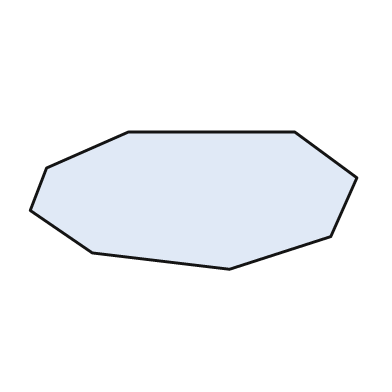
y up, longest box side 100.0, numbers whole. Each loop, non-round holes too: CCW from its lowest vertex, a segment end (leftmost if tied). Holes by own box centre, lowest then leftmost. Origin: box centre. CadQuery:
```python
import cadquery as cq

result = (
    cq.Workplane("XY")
    .moveTo(11.0, -21.0)
    .lineTo(42.0, -11.0)
    .lineTo(50.0, 7.0)
    .lineTo(31.0, 21.0)
    .lineTo(-20.0, 21.0)
    .lineTo(-45.0, 10.0)
    .lineTo(-50.0, -3.0)
    .lineTo(-31.0, -16.0)
    .close()
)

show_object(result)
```